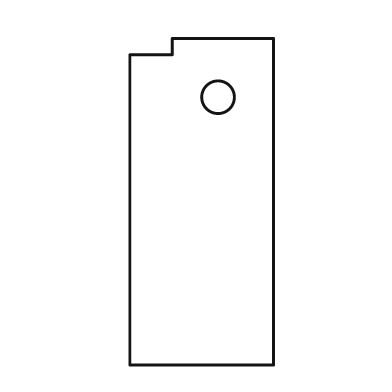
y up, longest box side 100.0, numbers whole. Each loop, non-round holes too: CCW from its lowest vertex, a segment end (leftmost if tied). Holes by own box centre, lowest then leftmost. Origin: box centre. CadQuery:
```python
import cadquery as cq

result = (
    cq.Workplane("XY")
    .moveTo(-22.0, -50.0)
    .lineTo(22.0, -50.0)
    .lineTo(22.0, 50.0)
    .lineTo(-9.0, 50.0)
    .lineTo(-9.0, 45.0)
    .lineTo(-22.0, 45.0)
    .close()
    .moveTo(5.0, 32.0)
    .circle(5.0)
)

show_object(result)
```